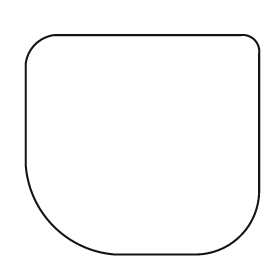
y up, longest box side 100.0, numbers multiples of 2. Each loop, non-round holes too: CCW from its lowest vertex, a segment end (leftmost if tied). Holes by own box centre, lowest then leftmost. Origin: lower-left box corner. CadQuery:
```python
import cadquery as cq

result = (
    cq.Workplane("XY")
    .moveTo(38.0, 0.0)
    .lineTo(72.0, 0.0)
    .threePointArc((92.0, 8.0), (100.0, 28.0))
    .lineTo(100.0, 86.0)
    .threePointArc((98.0, 92.0), (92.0, 94.0))
    .lineTo(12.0, 94.0)
    .threePointArc((4.0, 90.0), (0.0, 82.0))
    .lineTo(0.0, 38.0)
    .threePointArc((12.0, 12.0), (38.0, 0.0))
    .close()
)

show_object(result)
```